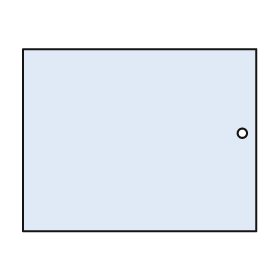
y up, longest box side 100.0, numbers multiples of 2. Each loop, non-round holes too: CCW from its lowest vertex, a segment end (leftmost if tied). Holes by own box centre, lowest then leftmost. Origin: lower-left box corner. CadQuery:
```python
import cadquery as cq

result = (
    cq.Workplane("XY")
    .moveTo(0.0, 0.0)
    .lineTo(100.0, 0.0)
    .lineTo(100.0, 78.0)
    .lineTo(0.0, 78.0)
    .close()
    .moveTo(94.0, 42.0)
    .circle(2.0)
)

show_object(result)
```